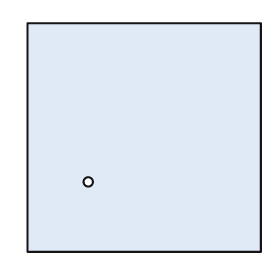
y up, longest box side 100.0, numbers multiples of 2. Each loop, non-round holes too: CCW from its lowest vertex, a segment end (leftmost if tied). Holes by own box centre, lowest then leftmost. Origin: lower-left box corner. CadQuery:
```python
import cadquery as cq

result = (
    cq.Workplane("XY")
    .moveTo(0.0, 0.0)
    .lineTo(100.0, 0.0)
    .lineTo(100.0, 98.0)
    .lineTo(0.0, 98.0)
    .close()
    .moveTo(26.0, 30.0)
    .circle(2.0)
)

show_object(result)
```